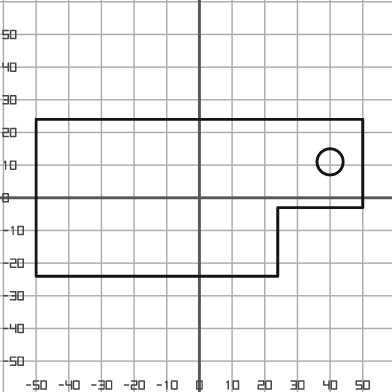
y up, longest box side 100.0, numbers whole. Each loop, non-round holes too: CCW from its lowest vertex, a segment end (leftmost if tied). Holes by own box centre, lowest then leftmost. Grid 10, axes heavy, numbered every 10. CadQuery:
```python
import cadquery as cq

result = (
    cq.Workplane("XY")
    .moveTo(-50.0, -24.0)
    .lineTo(24.0, -24.0)
    .lineTo(24.0, -3.0)
    .lineTo(50.0, -3.0)
    .lineTo(50.0, 24.0)
    .lineTo(-50.0, 24.0)
    .close()
    .moveTo(40.0, 11.0)
    .circle(4.0)
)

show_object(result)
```